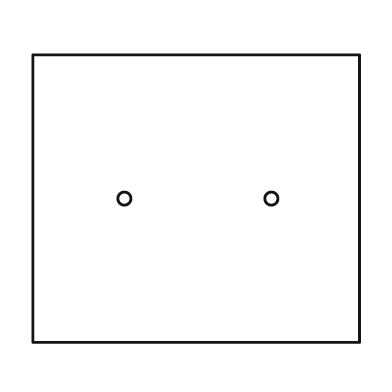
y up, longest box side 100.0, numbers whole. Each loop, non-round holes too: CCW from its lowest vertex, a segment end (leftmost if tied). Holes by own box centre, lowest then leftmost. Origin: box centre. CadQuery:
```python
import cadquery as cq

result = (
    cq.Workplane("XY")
    .moveTo(-50.0, -44.0)
    .lineTo(50.0, -44.0)
    .lineTo(50.0, 44.0)
    .lineTo(-50.0, 44.0)
    .close()
    .moveTo(-22.0, 0.0)
    .circle(2.0)
    .moveTo(23.0, 0.0)
    .circle(2.0)
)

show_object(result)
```